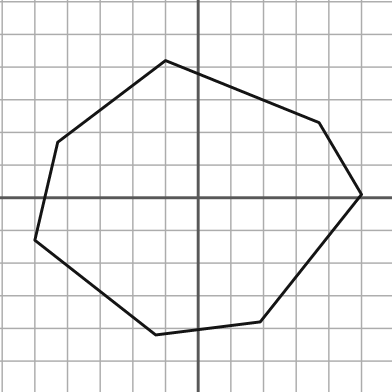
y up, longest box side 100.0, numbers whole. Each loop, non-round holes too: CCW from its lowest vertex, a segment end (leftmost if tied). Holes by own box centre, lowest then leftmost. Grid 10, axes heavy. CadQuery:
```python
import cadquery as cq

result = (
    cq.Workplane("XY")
    .moveTo(-13.0, -42.0)
    .lineTo(19.0, -38.0)
    .lineTo(50.0, 1.0)
    .lineTo(37.0, 23.0)
    .lineTo(-10.0, 42.0)
    .lineTo(-43.0, 17.0)
    .lineTo(-50.0, -13.0)
    .close()
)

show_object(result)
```